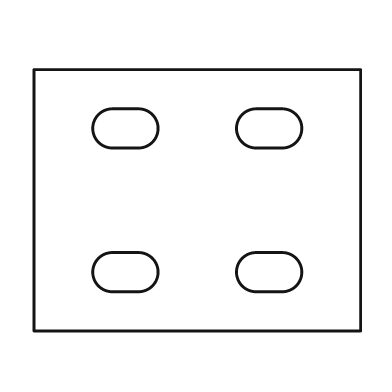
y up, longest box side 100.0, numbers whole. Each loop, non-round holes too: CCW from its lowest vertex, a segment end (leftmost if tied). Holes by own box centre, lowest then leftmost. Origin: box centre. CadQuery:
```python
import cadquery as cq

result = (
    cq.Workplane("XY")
    .moveTo(-50.0, -40.0)
    .lineTo(50.0, -40.0)
    .lineTo(50.0, 40.0)
    .lineTo(-50.0, 40.0)
    .close()
    .moveTo(-26.0, -28.0)
    .lineTo(-18.0, -28.0)
    .threePointArc((-12.0, -22.0), (-18.0, -16.0))
    .lineTo(-26.0, -16.0)
    .threePointArc((-32.0, -22.0), (-26.0, -28.0))
    .close()
    .moveTo(18.0, -28.0)
    .lineTo(26.0, -28.0)
    .threePointArc((32.0, -22.0), (26.0, -16.0))
    .lineTo(18.0, -16.0)
    .threePointArc((12.0, -22.0), (18.0, -28.0))
    .close()
    .moveTo(-26.0, 16.0)
    .lineTo(-18.0, 16.0)
    .threePointArc((-12.0, 22.0), (-18.0, 28.0))
    .lineTo(-26.0, 28.0)
    .threePointArc((-32.0, 22.0), (-26.0, 16.0))
    .close()
    .moveTo(18.0, 16.0)
    .lineTo(26.0, 16.0)
    .threePointArc((32.0, 22.0), (26.0, 28.0))
    .lineTo(18.0, 28.0)
    .threePointArc((12.0, 22.0), (18.0, 16.0))
    .close()
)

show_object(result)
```